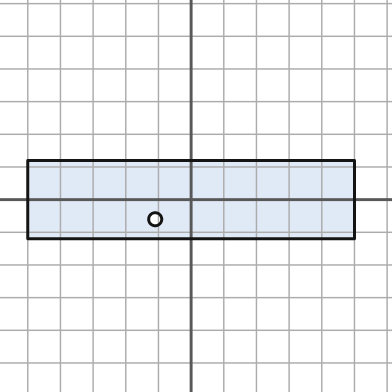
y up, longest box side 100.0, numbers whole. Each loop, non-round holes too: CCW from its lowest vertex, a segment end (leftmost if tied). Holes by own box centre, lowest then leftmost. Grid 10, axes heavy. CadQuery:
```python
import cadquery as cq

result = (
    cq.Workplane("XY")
    .moveTo(-50.0, -12.0)
    .lineTo(50.0, -12.0)
    .lineTo(50.0, 12.0)
    .lineTo(-50.0, 12.0)
    .close()
    .moveTo(-11.0, -6.0)
    .circle(2.0)
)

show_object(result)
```